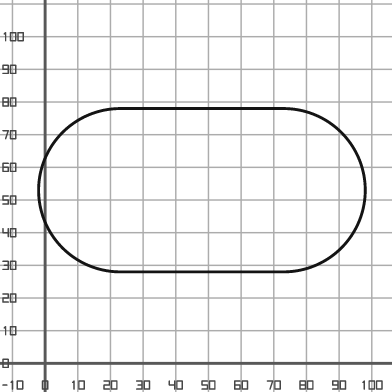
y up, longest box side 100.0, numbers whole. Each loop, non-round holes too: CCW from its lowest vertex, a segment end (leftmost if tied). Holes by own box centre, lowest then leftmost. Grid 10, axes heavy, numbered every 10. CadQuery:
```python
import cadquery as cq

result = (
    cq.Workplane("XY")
    .moveTo(23.0, 28.0)
    .lineTo(73.0, 28.0)
    .threePointArc((98.0, 53.0), (73.0, 78.0))
    .lineTo(23.0, 78.0)
    .threePointArc((-2.0, 53.0), (23.0, 28.0))
    .close()
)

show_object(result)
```